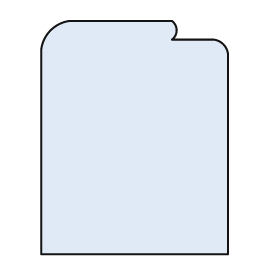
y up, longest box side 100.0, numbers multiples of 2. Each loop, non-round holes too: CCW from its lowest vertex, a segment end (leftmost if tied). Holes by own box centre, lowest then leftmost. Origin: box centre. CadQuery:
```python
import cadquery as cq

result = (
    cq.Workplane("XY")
    .moveTo(-40.0, -50.0)
    .lineTo(40.0, -50.0)
    .lineTo(40.0, 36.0)
    .threePointArc((38.0, 40.0), (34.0, 42.0))
    .lineTo(16.0, 42.0)
    .threePointArc((18.0, 46.0), (16.0, 50.0))
    .lineTo(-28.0, 50.0)
    .threePointArc((-36.0, 46.0), (-40.0, 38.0))
    .close()
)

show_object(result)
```